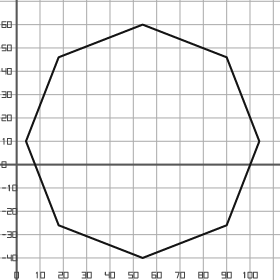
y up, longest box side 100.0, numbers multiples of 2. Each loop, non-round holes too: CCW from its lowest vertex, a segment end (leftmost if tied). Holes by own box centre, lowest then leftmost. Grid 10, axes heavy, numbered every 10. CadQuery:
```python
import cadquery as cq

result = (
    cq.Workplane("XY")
    .moveTo(54.0, -40.0)
    .lineTo(90.0, -26.0)
    .lineTo(104.0, 10.0)
    .lineTo(90.0, 46.0)
    .lineTo(54.0, 60.0)
    .lineTo(18.0, 46.0)
    .lineTo(4.0, 10.0)
    .lineTo(18.0, -26.0)
    .close()
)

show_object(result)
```